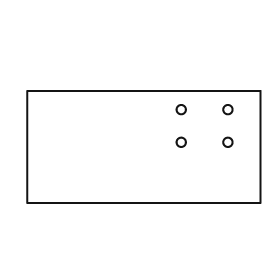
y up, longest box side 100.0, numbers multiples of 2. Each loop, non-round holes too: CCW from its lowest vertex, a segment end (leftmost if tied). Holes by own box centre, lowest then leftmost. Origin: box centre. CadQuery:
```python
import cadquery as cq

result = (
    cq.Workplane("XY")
    .moveTo(-50.0, -24.0)
    .lineTo(50.0, -24.0)
    .lineTo(50.0, 24.0)
    .lineTo(-50.0, 24.0)
    .close()
    .moveTo(16.0, 2.0)
    .circle(2.0)
    .moveTo(36.0, 2.0)
    .circle(2.0)
    .moveTo(16.0, 16.0)
    .circle(2.0)
    .moveTo(36.0, 16.0)
    .circle(2.0)
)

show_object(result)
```